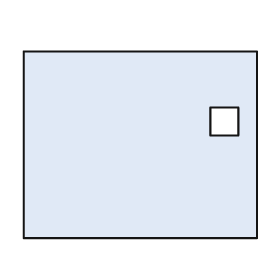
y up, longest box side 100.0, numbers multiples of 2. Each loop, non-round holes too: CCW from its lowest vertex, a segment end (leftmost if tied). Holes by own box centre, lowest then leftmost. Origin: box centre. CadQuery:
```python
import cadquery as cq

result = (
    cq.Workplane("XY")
    .moveTo(-50.0, -40.0)
    .lineTo(50.0, -40.0)
    .lineTo(50.0, 40.0)
    .lineTo(-50.0, 40.0)
    .close()
    .moveTo(30.0, 4.0)
    .lineTo(42.0, 4.0)
    .lineTo(42.0, 16.0)
    .lineTo(30.0, 16.0)
    .close()
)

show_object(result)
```